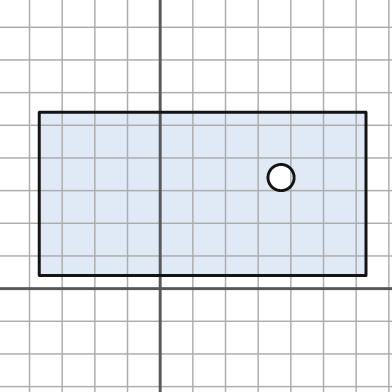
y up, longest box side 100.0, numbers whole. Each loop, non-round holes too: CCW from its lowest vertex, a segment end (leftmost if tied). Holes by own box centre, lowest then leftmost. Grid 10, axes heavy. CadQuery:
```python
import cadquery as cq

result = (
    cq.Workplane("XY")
    .moveTo(-37.0, 4.0)
    .lineTo(63.0, 4.0)
    .lineTo(63.0, 54.0)
    .lineTo(-37.0, 54.0)
    .close()
    .moveTo(37.0, 34.0)
    .circle(4.0)
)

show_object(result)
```